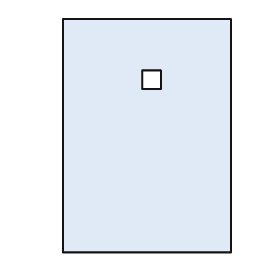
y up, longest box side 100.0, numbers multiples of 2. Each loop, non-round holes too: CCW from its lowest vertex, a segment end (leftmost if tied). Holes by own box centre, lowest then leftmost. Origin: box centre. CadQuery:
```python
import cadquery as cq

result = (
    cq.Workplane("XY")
    .moveTo(-36.0, -50.0)
    .lineTo(36.0, -50.0)
    .lineTo(36.0, 50.0)
    .lineTo(-36.0, 50.0)
    .close()
    .moveTo(-2.0, 20.0)
    .lineTo(6.0, 20.0)
    .lineTo(6.0, 28.0)
    .lineTo(-2.0, 28.0)
    .close()
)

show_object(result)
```